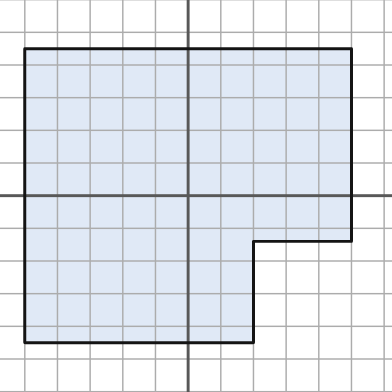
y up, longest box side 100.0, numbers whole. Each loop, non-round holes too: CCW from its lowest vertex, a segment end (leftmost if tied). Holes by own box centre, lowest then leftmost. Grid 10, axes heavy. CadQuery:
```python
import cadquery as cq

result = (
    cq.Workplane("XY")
    .moveTo(-50.0, -45.0)
    .lineTo(20.0, -45.0)
    .lineTo(20.0, -14.0)
    .lineTo(50.0, -14.0)
    .lineTo(50.0, 45.0)
    .lineTo(-50.0, 45.0)
    .close()
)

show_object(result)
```